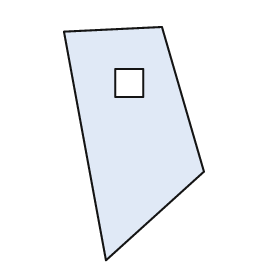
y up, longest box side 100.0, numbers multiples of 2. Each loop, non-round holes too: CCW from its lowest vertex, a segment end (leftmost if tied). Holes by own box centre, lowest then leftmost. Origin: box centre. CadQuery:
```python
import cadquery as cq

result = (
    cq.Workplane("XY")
    .moveTo(-12.0, -50.0)
    .lineTo(30.0, -12.0)
    .lineTo(12.0, 50.0)
    .lineTo(-30.0, 48.0)
    .close()
    .moveTo(-8.0, 20.0)
    .lineTo(4.0, 20.0)
    .lineTo(4.0, 32.0)
    .lineTo(-8.0, 32.0)
    .close()
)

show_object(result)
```